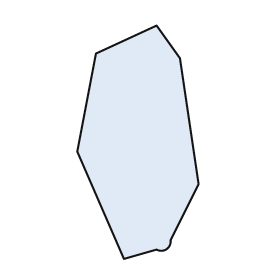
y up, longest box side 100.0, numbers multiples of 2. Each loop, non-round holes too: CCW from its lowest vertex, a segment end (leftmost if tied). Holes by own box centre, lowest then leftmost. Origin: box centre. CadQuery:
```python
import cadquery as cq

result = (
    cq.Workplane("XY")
    .moveTo(-6.0, -50.0)
    .lineTo(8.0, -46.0)
    .threePointArc((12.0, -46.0), (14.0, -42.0))
    .lineTo(26.0, -18.0)
    .lineTo(18.0, 36.0)
    .lineTo(8.0, 50.0)
    .lineTo(-18.0, 38.0)
    .lineTo(-26.0, -4.0)
    .close()
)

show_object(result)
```